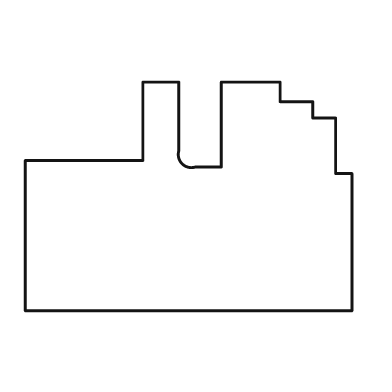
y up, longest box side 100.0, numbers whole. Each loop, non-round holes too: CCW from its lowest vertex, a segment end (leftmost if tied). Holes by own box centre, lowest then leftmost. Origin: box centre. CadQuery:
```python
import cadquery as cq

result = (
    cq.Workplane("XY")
    .moveTo(-50.0, -35.0)
    .lineTo(50.0, -35.0)
    .lineTo(50.0, 7.0)
    .lineTo(45.0, 7.0)
    .lineTo(45.0, 24.0)
    .lineTo(38.0, 24.0)
    .lineTo(38.0, 29.0)
    .lineTo(28.0, 29.0)
    .lineTo(28.0, 35.0)
    .lineTo(10.0, 35.0)
    .lineTo(10.0, 9.0)
    .lineTo(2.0, 9.0)
    .threePointArc((-2.0, 10.0), (-3.0, 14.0))
    .lineTo(-3.0, 35.0)
    .lineTo(-14.0, 35.0)
    .lineTo(-14.0, 11.0)
    .lineTo(-50.0, 11.0)
    .close()
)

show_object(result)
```